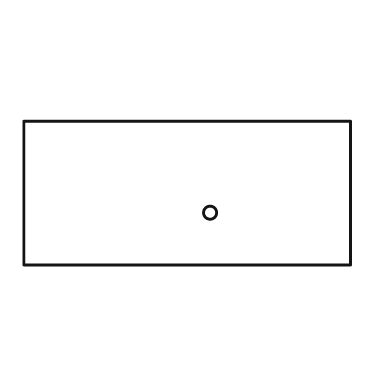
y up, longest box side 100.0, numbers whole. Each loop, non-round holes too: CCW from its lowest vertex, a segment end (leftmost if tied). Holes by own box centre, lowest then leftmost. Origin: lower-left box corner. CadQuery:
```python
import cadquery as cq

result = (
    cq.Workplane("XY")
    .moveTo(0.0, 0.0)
    .lineTo(100.0, 0.0)
    .lineTo(100.0, 44.0)
    .lineTo(0.0, 44.0)
    .close()
    .moveTo(57.0, 16.0)
    .circle(2.0)
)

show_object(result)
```